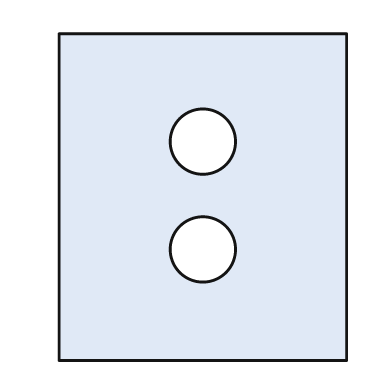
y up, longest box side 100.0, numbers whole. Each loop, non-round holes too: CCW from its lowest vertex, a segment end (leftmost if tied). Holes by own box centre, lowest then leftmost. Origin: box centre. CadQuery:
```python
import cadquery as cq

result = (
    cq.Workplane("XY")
    .moveTo(-44.0, -50.0)
    .lineTo(44.0, -50.0)
    .lineTo(44.0, 50.0)
    .lineTo(-44.0, 50.0)
    .close()
    .moveTo(0.0, -16.0)
    .circle(10.0)
    .moveTo(0.0, 17.0)
    .circle(10.0)
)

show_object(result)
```